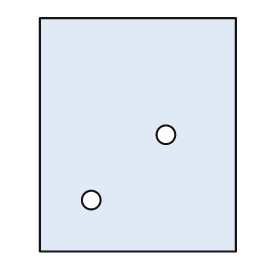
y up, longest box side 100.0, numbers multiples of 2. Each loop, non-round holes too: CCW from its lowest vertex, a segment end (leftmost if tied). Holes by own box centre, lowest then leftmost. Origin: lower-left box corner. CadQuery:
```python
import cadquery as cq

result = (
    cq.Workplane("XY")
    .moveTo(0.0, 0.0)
    .lineTo(84.0, 0.0)
    .lineTo(84.0, 100.0)
    .lineTo(0.0, 100.0)
    .close()
    .moveTo(22.0, 22.0)
    .circle(4.0)
    .moveTo(54.0, 50.0)
    .circle(4.0)
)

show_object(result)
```